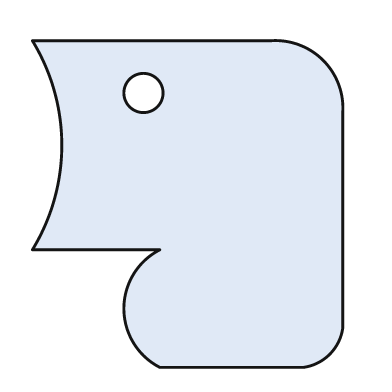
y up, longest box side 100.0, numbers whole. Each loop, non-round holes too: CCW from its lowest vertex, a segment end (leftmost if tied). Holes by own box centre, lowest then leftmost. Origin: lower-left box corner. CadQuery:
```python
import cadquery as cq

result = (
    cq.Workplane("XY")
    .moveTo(39.0, 0.0)
    .lineTo(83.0, 0.0)
    .threePointArc((91.0, 4.0), (95.0, 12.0))
    .lineTo(95.0, 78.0)
    .threePointArc((89.0, 94.0), (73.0, 100.0))
    .lineTo(0.0, 100.0)
    .threePointArc((9.0, 68.0), (0.0, 36.0))
    .lineTo(39.0, 36.0)
    .threePointArc((28.0, 18.0), (39.0, 0.0))
    .close()
    .moveTo(34.0, 84.0)
    .circle(6.0)
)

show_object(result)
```